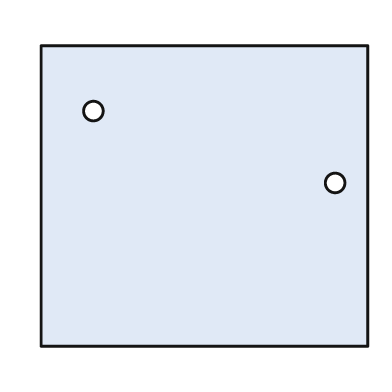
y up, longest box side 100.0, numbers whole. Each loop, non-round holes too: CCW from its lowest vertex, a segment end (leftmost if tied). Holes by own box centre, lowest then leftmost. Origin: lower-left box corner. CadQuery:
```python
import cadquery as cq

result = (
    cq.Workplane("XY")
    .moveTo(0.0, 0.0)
    .lineTo(100.0, 0.0)
    .lineTo(100.0, 92.0)
    .lineTo(0.0, 92.0)
    .close()
    .moveTo(90.0, 50.0)
    .circle(3.0)
    .moveTo(16.0, 72.0)
    .circle(3.0)
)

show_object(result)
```